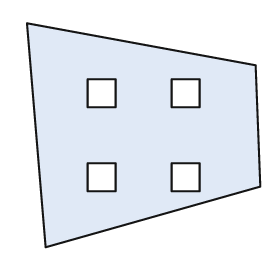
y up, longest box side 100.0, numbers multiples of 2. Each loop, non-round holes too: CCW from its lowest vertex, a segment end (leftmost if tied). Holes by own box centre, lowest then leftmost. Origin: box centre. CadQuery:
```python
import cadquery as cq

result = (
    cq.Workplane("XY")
    .moveTo(-42.0, -48.0)
    .lineTo(50.0, -22.0)
    .lineTo(48.0, 30.0)
    .lineTo(-50.0, 48.0)
    .close()
    .moveTo(-24.0, -24.0)
    .lineTo(-12.0, -24.0)
    .lineTo(-12.0, -12.0)
    .lineTo(-24.0, -12.0)
    .close()
    .moveTo(12.0, -24.0)
    .lineTo(24.0, -24.0)
    .lineTo(24.0, -12.0)
    .lineTo(12.0, -12.0)
    .close()
    .moveTo(-24.0, 12.0)
    .lineTo(-12.0, 12.0)
    .lineTo(-12.0, 24.0)
    .lineTo(-24.0, 24.0)
    .close()
    .moveTo(12.0, 12.0)
    .lineTo(24.0, 12.0)
    .lineTo(24.0, 24.0)
    .lineTo(12.0, 24.0)
    .close()
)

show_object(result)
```